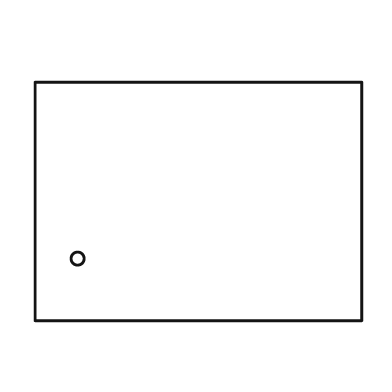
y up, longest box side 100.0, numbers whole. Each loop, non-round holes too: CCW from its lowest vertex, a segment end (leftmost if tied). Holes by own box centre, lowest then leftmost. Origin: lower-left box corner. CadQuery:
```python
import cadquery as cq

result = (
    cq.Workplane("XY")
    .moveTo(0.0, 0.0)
    .lineTo(100.0, 0.0)
    .lineTo(100.0, 73.0)
    .lineTo(0.0, 73.0)
    .close()
    .moveTo(13.0, 19.0)
    .circle(2.0)
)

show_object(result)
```